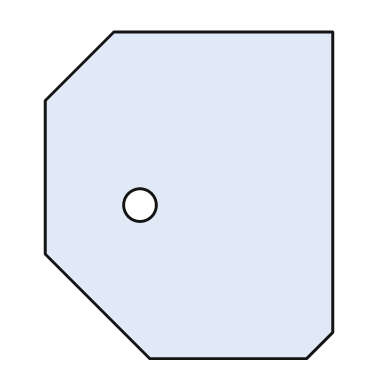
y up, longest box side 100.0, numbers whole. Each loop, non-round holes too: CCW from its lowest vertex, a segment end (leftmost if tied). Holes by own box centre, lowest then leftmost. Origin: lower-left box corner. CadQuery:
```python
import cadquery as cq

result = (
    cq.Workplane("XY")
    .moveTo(32.0, 0.0)
    .lineTo(80.0, 0.0)
    .lineTo(88.0, 8.0)
    .lineTo(88.0, 100.0)
    .lineTo(21.0, 100.0)
    .lineTo(0.0, 79.0)
    .lineTo(0.0, 32.0)
    .close()
    .moveTo(29.0, 47.0)
    .circle(5.0)
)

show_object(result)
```